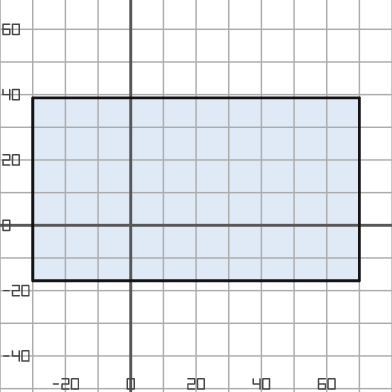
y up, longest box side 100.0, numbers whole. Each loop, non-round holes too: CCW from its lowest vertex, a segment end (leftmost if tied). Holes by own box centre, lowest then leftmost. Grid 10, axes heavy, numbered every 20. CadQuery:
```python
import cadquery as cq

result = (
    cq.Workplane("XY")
    .moveTo(-30.0, -17.0)
    .lineTo(70.0, -17.0)
    .lineTo(70.0, 39.0)
    .lineTo(-30.0, 39.0)
    .close()
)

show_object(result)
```